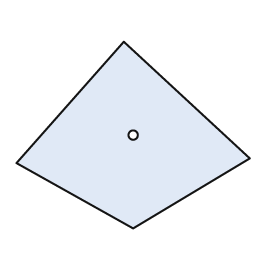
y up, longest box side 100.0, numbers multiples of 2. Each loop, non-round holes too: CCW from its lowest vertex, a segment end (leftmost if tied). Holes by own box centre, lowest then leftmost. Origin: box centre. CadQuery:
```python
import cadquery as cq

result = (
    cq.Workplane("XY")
    .moveTo(0.0, -40.0)
    .lineTo(50.0, -10.0)
    .lineTo(-4.0, 40.0)
    .lineTo(-50.0, -12.0)
    .close()
    .moveTo(0.0, 0.0)
    .circle(2.0)
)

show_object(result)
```